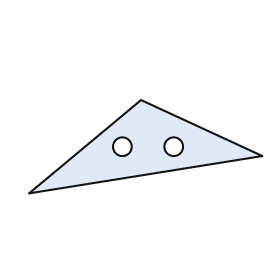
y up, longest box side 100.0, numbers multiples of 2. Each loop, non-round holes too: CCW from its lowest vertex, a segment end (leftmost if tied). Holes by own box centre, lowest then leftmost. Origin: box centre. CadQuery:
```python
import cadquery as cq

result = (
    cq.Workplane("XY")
    .moveTo(-50.0, -20.0)
    .lineTo(50.0, -4.0)
    .lineTo(-2.0, 20.0)
    .close()
    .moveTo(-10.0, 0.0)
    .circle(4.0)
    .moveTo(12.0, 0.0)
    .circle(4.0)
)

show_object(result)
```